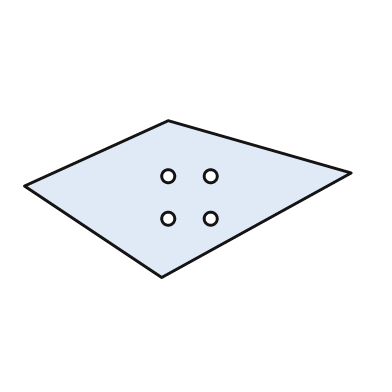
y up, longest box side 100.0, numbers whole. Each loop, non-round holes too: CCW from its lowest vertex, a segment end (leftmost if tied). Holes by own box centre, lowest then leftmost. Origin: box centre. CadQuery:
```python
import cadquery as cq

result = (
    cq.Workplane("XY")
    .moveTo(-8.0, -24.0)
    .lineTo(50.0, 8.0)
    .lineTo(-6.0, 24.0)
    .lineTo(-50.0, 4.0)
    .close()
    .moveTo(-6.0, -6.0)
    .circle(2.0)
    .moveTo(7.0, -6.0)
    .circle(2.0)
    .moveTo(-6.0, 7.0)
    .circle(2.0)
    .moveTo(7.0, 7.0)
    .circle(2.0)
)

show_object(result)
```